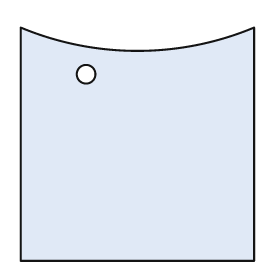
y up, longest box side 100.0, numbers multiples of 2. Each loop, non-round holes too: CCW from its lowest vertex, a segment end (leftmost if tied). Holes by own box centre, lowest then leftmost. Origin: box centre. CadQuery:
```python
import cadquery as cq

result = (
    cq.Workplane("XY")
    .moveTo(-50.0, -50.0)
    .lineTo(50.0, -50.0)
    .lineTo(50.0, 50.0)
    .threePointArc((0.0, 40.0), (-50.0, 50.0))
    .close()
    .moveTo(-22.0, 30.0)
    .circle(4.0)
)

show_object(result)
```